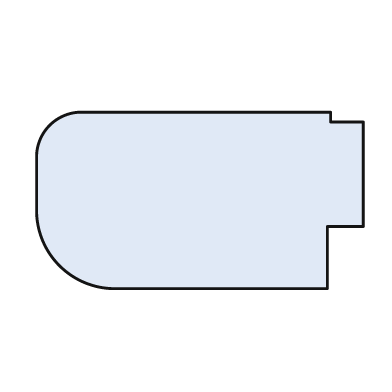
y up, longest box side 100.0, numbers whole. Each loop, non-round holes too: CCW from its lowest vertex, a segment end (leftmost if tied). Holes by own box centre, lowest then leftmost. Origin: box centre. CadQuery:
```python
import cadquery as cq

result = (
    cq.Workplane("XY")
    .moveTo(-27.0, -27.0)
    .lineTo(39.0, -27.0)
    .lineTo(39.0, -8.0)
    .lineTo(50.0, -8.0)
    .lineTo(50.0, 24.0)
    .lineTo(40.0, 24.0)
    .lineTo(40.0, 27.0)
    .lineTo(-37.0, 27.0)
    .threePointArc((-46.0, 23.0), (-50.0, 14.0))
    .lineTo(-50.0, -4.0)
    .threePointArc((-43.0, -20.0), (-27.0, -27.0))
    .close()
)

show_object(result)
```